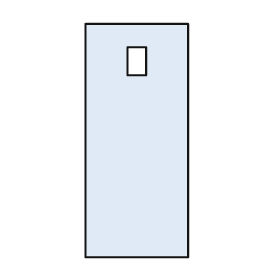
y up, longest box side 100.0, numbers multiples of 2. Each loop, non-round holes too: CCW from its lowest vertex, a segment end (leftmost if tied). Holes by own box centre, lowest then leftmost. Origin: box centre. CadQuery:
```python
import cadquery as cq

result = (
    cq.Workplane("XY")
    .moveTo(-22.0, -50.0)
    .lineTo(22.0, -50.0)
    .lineTo(22.0, 50.0)
    .lineTo(-22.0, 50.0)
    .close()
    .moveTo(-4.0, 28.0)
    .lineTo(4.0, 28.0)
    .lineTo(4.0, 40.0)
    .lineTo(-4.0, 40.0)
    .close()
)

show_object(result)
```